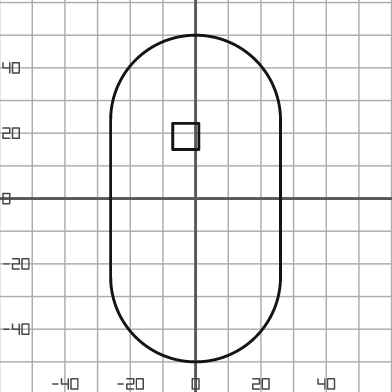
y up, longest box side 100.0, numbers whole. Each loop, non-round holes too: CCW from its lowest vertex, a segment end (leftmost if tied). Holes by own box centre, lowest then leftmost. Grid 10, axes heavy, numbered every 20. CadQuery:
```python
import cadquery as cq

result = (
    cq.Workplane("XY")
    .moveTo(-26.0, -24.0)
    .threePointArc((0.0, -50.0), (26.0, -24.0))
    .lineTo(26.0, 24.0)
    .threePointArc((0.0, 50.0), (-26.0, 24.0))
    .close()
    .moveTo(-7.0, 15.0)
    .lineTo(1.0, 15.0)
    .lineTo(1.0, 23.0)
    .lineTo(-7.0, 23.0)
    .close()
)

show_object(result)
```